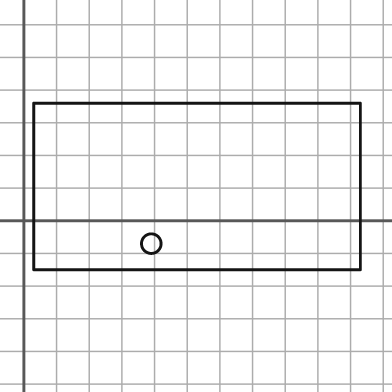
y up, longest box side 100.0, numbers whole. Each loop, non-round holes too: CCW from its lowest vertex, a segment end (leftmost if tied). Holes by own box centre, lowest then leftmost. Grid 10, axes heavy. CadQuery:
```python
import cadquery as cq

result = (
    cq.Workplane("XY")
    .moveTo(3.0, -15.0)
    .lineTo(103.0, -15.0)
    .lineTo(103.0, 36.0)
    .lineTo(3.0, 36.0)
    .close()
    .moveTo(39.0, -7.0)
    .circle(3.0)
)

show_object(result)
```